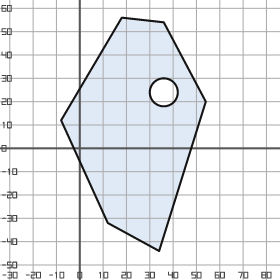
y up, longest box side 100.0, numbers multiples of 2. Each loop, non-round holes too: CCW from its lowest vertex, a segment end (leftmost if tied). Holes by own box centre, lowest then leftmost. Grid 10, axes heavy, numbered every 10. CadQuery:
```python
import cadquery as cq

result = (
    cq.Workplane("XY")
    .moveTo(34.0, -44.0)
    .lineTo(54.0, 20.0)
    .lineTo(36.0, 54.0)
    .lineTo(18.0, 56.0)
    .lineTo(-8.0, 12.0)
    .lineTo(12.0, -32.0)
    .close()
    .moveTo(36.0, 24.0)
    .circle(6.0)
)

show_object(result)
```